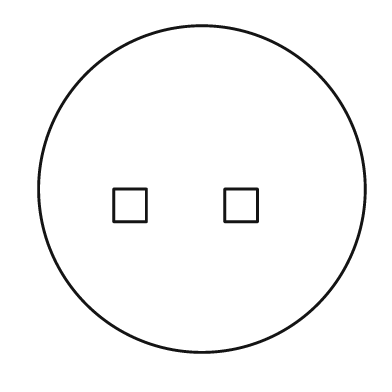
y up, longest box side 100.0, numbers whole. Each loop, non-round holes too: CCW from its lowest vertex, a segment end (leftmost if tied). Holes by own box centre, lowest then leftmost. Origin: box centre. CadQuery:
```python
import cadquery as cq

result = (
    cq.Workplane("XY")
    .moveTo(0.0, 0.0)
    .circle(50.0)
    .moveTo(-27.0, -10.0)
    .lineTo(-17.0, -10.0)
    .lineTo(-17.0, 0.0)
    .lineTo(-27.0, 0.0)
    .close()
    .moveTo(7.0, -10.0)
    .lineTo(17.0, -10.0)
    .lineTo(17.0, 0.0)
    .lineTo(7.0, 0.0)
    .close()
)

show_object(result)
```